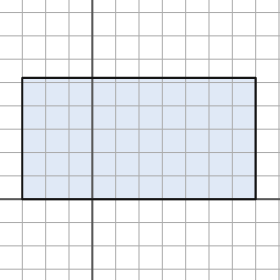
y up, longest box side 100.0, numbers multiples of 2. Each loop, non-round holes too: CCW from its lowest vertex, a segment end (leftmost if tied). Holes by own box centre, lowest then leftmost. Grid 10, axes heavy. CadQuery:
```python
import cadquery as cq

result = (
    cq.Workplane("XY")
    .moveTo(-30.0, 0.0)
    .lineTo(70.0, 0.0)
    .lineTo(70.0, 52.0)
    .lineTo(-30.0, 52.0)
    .close()
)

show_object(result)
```